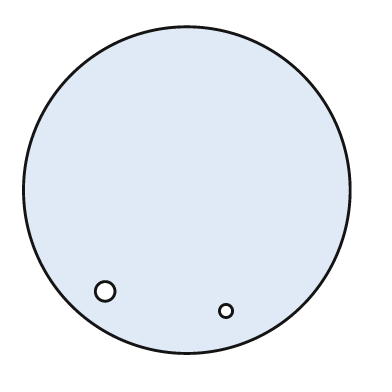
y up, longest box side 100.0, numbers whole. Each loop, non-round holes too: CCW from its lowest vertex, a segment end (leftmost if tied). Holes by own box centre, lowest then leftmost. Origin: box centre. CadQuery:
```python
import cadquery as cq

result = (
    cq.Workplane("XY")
    .moveTo(0.0, 0.0)
    .circle(50.0)
    .moveTo(12.0, -37.0)
    .circle(2.0)
    .moveTo(-25.0, -31.0)
    .circle(3.0)
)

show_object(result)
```